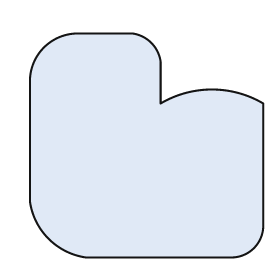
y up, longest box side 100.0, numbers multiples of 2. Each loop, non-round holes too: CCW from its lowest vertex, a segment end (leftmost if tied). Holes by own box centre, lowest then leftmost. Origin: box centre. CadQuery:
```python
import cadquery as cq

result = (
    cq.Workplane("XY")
    .moveTo(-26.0, -48.0)
    .lineTo(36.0, -48.0)
    .threePointArc((46.0, -44.0), (50.0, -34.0))
    .lineTo(50.0, 18.0)
    .threePointArc((28.0, 24.0), (6.0, 18.0))
    .lineTo(6.0, 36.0)
    .threePointArc((2.0, 44.0), (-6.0, 48.0))
    .lineTo(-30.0, 48.0)
    .threePointArc((-44.0, 42.0), (-50.0, 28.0))
    .lineTo(-50.0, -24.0)
    .threePointArc((-42.0, -40.0), (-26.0, -48.0))
    .close()
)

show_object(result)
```